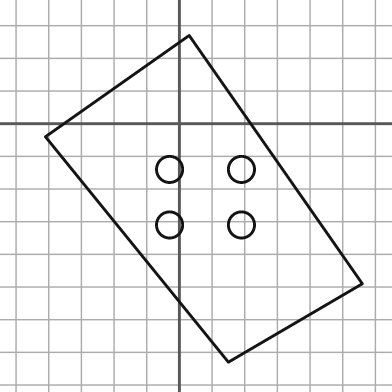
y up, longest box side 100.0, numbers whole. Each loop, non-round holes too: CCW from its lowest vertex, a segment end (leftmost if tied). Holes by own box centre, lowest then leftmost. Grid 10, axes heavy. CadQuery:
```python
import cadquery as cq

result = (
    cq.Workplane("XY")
    .moveTo(15.0, -73.0)
    .lineTo(56.0, -49.0)
    .lineTo(3.0, 27.0)
    .lineTo(-41.0, -4.0)
    .close()
    .moveTo(-3.0, -31.0)
    .circle(4.0)
    .moveTo(19.0, -31.0)
    .circle(4.0)
    .moveTo(-3.0, -14.0)
    .circle(4.0)
    .moveTo(19.0, -14.0)
    .circle(4.0)
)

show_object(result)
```